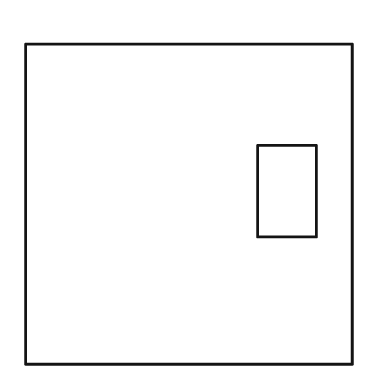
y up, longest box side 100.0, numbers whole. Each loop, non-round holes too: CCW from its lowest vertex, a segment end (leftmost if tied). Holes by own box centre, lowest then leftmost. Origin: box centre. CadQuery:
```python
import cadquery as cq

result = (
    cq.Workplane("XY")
    .moveTo(-50.0, -49.0)
    .lineTo(50.0, -49.0)
    .lineTo(50.0, 49.0)
    .lineTo(-50.0, 49.0)
    .close()
    .moveTo(21.0, -10.0)
    .lineTo(39.0, -10.0)
    .lineTo(39.0, 18.0)
    .lineTo(21.0, 18.0)
    .close()
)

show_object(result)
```